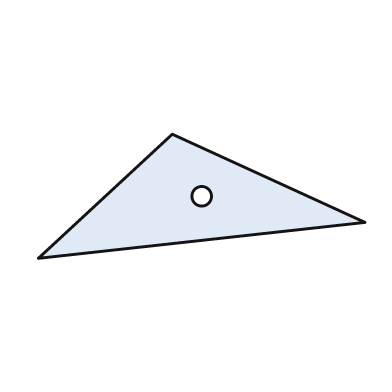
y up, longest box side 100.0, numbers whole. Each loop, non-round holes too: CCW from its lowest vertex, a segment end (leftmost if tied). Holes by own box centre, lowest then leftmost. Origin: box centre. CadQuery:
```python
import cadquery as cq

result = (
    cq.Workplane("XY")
    .moveTo(-50.0, -19.0)
    .lineTo(50.0, -8.0)
    .lineTo(-9.0, 19.0)
    .close()
    .moveTo(0.0, 0.0)
    .circle(3.0)
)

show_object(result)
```